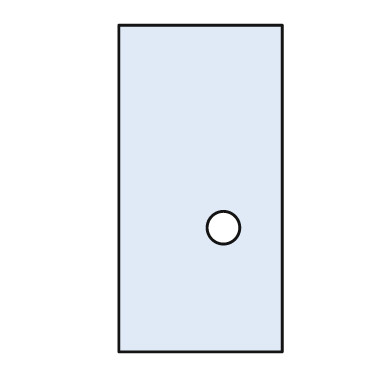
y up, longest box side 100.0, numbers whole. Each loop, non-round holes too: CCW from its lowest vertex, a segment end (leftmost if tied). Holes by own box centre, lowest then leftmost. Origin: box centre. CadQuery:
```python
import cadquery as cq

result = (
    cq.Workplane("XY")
    .moveTo(-25.0, -50.0)
    .lineTo(25.0, -50.0)
    .lineTo(25.0, 50.0)
    .lineTo(-25.0, 50.0)
    .close()
    .moveTo(7.0, -12.0)
    .circle(5.0)
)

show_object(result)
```